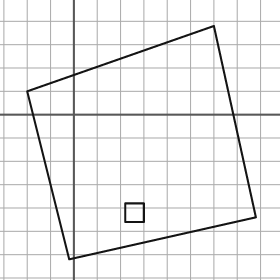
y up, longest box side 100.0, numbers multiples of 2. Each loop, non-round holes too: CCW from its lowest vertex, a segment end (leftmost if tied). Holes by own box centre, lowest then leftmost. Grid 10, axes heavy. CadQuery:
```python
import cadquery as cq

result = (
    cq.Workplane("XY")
    .moveTo(-2.0, -62.0)
    .lineTo(78.0, -44.0)
    .lineTo(60.0, 38.0)
    .lineTo(-20.0, 10.0)
    .close()
    .moveTo(22.0, -46.0)
    .lineTo(30.0, -46.0)
    .lineTo(30.0, -38.0)
    .lineTo(22.0, -38.0)
    .close()
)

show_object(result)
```